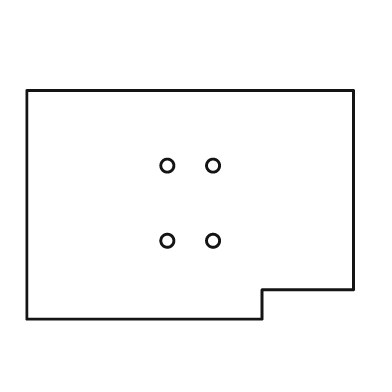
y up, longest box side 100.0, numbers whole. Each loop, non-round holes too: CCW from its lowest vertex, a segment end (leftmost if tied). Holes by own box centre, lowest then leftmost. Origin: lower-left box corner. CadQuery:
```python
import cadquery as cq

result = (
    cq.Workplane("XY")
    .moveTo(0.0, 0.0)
    .lineTo(72.0, 0.0)
    .lineTo(72.0, 9.0)
    .lineTo(100.0, 9.0)
    .lineTo(100.0, 70.0)
    .lineTo(0.0, 70.0)
    .close()
    .moveTo(43.0, 24.0)
    .circle(2.0)
    .moveTo(57.0, 24.0)
    .circle(2.0)
    .moveTo(43.0, 47.0)
    .circle(2.0)
    .moveTo(57.0, 47.0)
    .circle(2.0)
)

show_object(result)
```